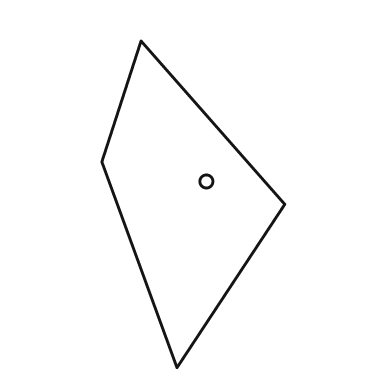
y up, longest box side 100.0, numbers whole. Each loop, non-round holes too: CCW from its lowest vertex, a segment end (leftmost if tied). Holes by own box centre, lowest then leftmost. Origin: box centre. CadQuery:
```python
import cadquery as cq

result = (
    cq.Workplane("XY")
    .moveTo(-5.0, -50.0)
    .lineTo(28.0, 0.0)
    .lineTo(-16.0, 50.0)
    .lineTo(-28.0, 13.0)
    .close()
    .moveTo(4.0, 7.0)
    .circle(2.0)
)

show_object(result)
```